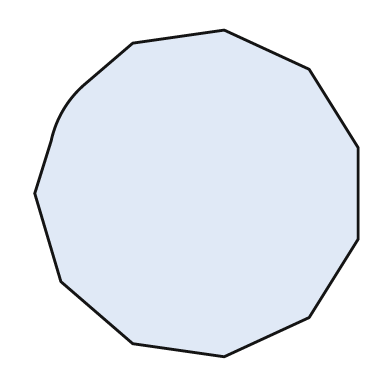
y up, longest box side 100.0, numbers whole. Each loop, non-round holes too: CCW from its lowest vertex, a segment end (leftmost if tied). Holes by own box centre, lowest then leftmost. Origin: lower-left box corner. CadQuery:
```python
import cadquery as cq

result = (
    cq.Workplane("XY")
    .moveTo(58.0, 0.0)
    .lineTo(84.0, 12.0)
    .lineTo(99.0, 36.0)
    .lineTo(99.0, 64.0)
    .lineTo(84.0, 88.0)
    .lineTo(58.0, 100.0)
    .lineTo(30.0, 96.0)
    .lineTo(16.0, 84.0)
    .threePointArc((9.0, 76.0), (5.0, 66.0))
    .lineTo(0.0, 50.0)
    .lineTo(8.0, 23.0)
    .lineTo(30.0, 4.0)
    .close()
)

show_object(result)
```